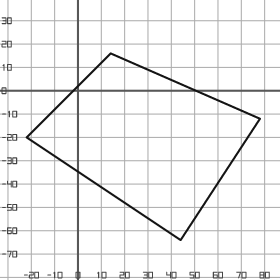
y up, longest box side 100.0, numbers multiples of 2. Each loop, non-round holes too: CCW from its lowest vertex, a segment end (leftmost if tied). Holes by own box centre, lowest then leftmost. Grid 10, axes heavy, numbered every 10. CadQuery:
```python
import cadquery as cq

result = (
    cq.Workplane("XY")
    .moveTo(44.0, -64.0)
    .lineTo(78.0, -12.0)
    .lineTo(14.0, 16.0)
    .lineTo(-22.0, -20.0)
    .close()
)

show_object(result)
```